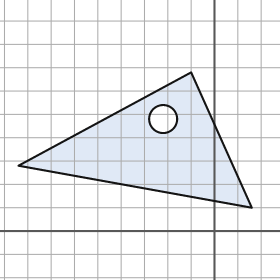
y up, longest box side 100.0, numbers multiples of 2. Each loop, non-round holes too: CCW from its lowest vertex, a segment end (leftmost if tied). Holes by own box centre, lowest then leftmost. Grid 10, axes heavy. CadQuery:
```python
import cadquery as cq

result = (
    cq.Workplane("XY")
    .moveTo(16.0, 10.0)
    .lineTo(-10.0, 68.0)
    .lineTo(-84.0, 28.0)
    .close()
    .moveTo(-22.0, 48.0)
    .circle(6.0)
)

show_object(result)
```